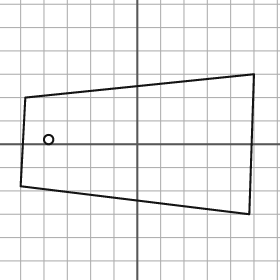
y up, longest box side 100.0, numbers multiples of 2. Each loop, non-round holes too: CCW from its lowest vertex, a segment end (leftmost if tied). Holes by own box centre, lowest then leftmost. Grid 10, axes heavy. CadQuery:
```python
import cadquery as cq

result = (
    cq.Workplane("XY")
    .moveTo(48.0, -30.0)
    .lineTo(50.0, 30.0)
    .lineTo(-48.0, 20.0)
    .lineTo(-50.0, -18.0)
    .close()
    .moveTo(-38.0, 2.0)
    .circle(2.0)
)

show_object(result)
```